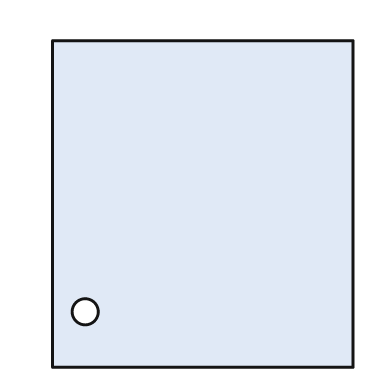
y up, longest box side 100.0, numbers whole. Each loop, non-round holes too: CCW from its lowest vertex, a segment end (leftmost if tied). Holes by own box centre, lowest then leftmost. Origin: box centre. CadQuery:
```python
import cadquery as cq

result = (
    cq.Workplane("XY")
    .moveTo(-46.0, -50.0)
    .lineTo(46.0, -50.0)
    .lineTo(46.0, 50.0)
    .lineTo(-46.0, 50.0)
    .close()
    .moveTo(-36.0, -33.0)
    .circle(4.0)
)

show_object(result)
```